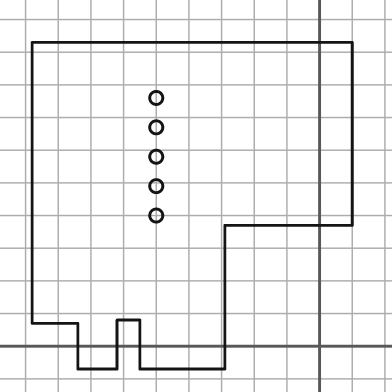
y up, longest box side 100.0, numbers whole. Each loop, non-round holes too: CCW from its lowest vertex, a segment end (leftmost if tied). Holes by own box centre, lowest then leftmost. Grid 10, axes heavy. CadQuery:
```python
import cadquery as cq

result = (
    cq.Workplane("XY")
    .moveTo(-74.0, -7.0)
    .lineTo(-62.0, -7.0)
    .lineTo(-62.0, 8.0)
    .lineTo(-55.0, 8.0)
    .lineTo(-55.0, -7.0)
    .lineTo(-29.0, -7.0)
    .lineTo(-29.0, 37.0)
    .lineTo(10.0, 37.0)
    .lineTo(10.0, 93.0)
    .lineTo(-88.0, 93.0)
    .lineTo(-88.0, 7.0)
    .lineTo(-74.0, 7.0)
    .close()
    .moveTo(-50.0, 40.0)
    .circle(2.0)
    .moveTo(-50.0, 49.0)
    .circle(2.0)
    .moveTo(-50.0, 58.0)
    .circle(2.0)
    .moveTo(-50.0, 67.0)
    .circle(2.0)
    .moveTo(-50.0, 76.0)
    .circle(2.0)
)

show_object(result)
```